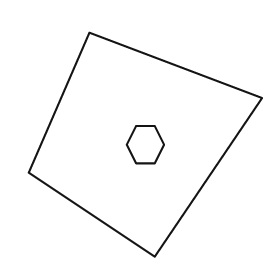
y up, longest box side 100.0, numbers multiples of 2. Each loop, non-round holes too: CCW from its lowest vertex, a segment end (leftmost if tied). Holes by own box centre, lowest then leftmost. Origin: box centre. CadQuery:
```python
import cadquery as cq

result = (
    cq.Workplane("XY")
    .moveTo(4.0, -48.0)
    .lineTo(50.0, 20.0)
    .lineTo(-24.0, 48.0)
    .lineTo(-50.0, -12.0)
    .close()
    .moveTo(-4.0, -8.0)
    .lineTo(4.0, -8.0)
    .lineTo(8.0, 0.0)
    .lineTo(4.0, 8.0)
    .lineTo(-4.0, 8.0)
    .lineTo(-8.0, 0.0)
    .close()
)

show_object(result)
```